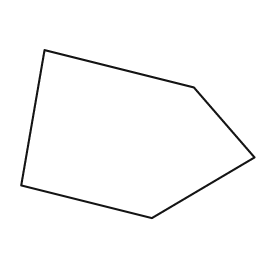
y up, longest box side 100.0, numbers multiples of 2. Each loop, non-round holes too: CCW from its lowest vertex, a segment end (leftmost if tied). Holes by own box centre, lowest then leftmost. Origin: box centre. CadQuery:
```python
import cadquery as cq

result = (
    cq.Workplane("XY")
    .moveTo(6.0, -36.0)
    .lineTo(50.0, -10.0)
    .lineTo(24.0, 20.0)
    .lineTo(-40.0, 36.0)
    .lineTo(-50.0, -22.0)
    .close()
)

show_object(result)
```